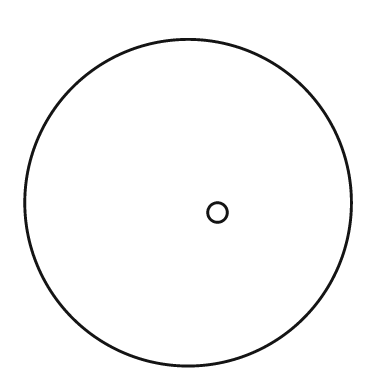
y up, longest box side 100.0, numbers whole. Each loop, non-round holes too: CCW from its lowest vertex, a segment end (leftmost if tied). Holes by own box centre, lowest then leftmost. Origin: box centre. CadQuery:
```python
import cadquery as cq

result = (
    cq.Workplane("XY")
    .moveTo(0.0, 0.0)
    .circle(50.0)
    .moveTo(9.0, -3.0)
    .circle(3.0)
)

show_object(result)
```